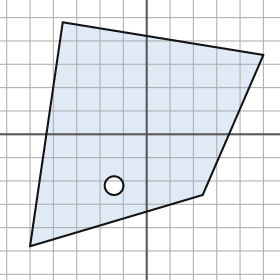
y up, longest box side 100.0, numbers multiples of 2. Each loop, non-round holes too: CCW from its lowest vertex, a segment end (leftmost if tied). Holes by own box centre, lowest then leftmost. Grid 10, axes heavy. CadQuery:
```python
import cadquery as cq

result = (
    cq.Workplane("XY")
    .moveTo(-50.0, -48.0)
    .lineTo(24.0, -26.0)
    .lineTo(50.0, 34.0)
    .lineTo(-36.0, 48.0)
    .close()
    .moveTo(-14.0, -22.0)
    .circle(4.0)
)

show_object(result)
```